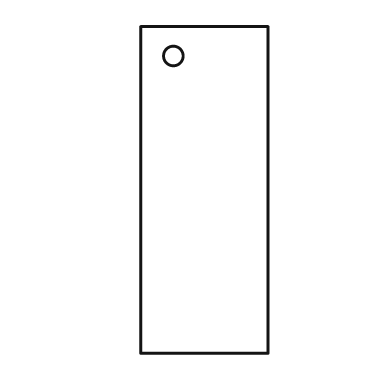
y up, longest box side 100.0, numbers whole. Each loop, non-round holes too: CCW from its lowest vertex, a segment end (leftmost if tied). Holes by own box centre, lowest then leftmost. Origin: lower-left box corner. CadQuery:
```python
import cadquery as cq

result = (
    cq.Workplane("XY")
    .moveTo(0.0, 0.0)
    .lineTo(39.0, 0.0)
    .lineTo(39.0, 100.0)
    .lineTo(0.0, 100.0)
    .close()
    .moveTo(10.0, 91.0)
    .circle(3.0)
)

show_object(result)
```